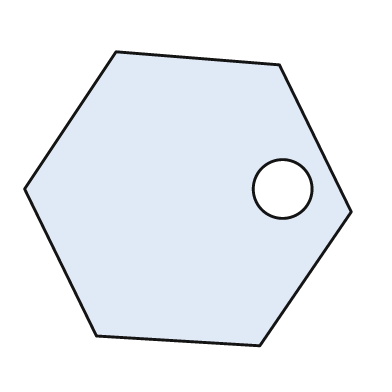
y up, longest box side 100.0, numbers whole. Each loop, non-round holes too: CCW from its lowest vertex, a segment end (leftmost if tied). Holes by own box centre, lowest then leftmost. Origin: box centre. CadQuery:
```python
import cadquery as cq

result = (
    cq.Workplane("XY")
    .moveTo(22.0, -45.0)
    .lineTo(50.0, -4.0)
    .lineTo(28.0, 41.0)
    .lineTo(-22.0, 45.0)
    .lineTo(-50.0, 3.0)
    .lineTo(-28.0, -42.0)
    .close()
    .moveTo(29.0, 3.0)
    .circle(9.0)
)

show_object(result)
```